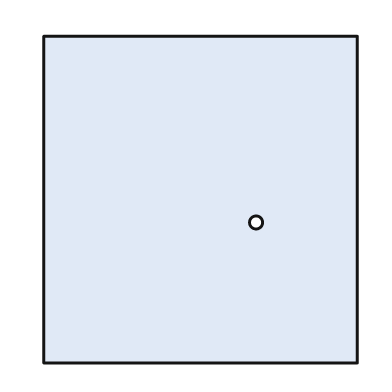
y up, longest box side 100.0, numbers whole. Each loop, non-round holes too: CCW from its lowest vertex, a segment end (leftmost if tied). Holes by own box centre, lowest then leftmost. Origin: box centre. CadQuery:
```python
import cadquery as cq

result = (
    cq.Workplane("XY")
    .moveTo(-48.0, -50.0)
    .lineTo(48.0, -50.0)
    .lineTo(48.0, 50.0)
    .lineTo(-48.0, 50.0)
    .close()
    .moveTo(17.0, -7.0)
    .circle(2.0)
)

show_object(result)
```